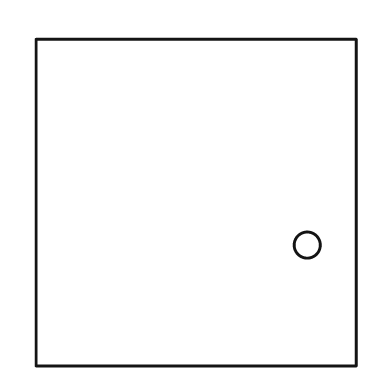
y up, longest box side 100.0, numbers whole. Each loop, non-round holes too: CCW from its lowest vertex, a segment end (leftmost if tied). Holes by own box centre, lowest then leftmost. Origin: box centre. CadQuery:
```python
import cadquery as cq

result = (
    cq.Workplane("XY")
    .moveTo(-49.0, -50.0)
    .lineTo(49.0, -50.0)
    .lineTo(49.0, 50.0)
    .lineTo(-49.0, 50.0)
    .close()
    .moveTo(34.0, -13.0)
    .circle(4.0)
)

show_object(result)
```